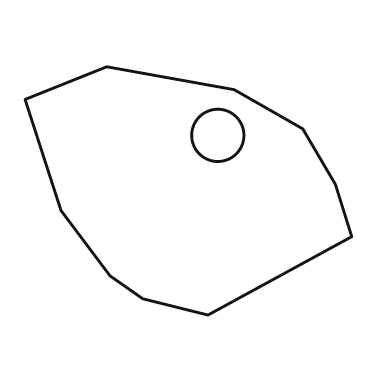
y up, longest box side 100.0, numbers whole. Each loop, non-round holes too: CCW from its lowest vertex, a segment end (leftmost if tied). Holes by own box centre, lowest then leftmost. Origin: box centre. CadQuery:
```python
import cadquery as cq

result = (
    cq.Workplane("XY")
    .moveTo(6.0, -38.0)
    .lineTo(50.0, -14.0)
    .lineTo(45.0, 2.0)
    .lineTo(35.0, 19.0)
    .lineTo(14.0, 31.0)
    .lineTo(-25.0, 38.0)
    .lineTo(-50.0, 28.0)
    .lineTo(-39.0, -6.0)
    .lineTo(-24.0, -26.0)
    .lineTo(-14.0, -33.0)
    .close()
    .moveTo(9.0, 17.0)
    .circle(8.0)
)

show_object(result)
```